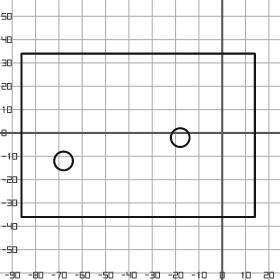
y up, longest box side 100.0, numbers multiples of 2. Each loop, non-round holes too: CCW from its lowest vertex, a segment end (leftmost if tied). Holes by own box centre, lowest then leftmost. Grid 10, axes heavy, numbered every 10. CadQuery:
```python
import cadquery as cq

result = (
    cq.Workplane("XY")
    .moveTo(-86.0, -36.0)
    .lineTo(14.0, -36.0)
    .lineTo(14.0, 34.0)
    .lineTo(-86.0, 34.0)
    .close()
    .moveTo(-68.0, -12.0)
    .circle(4.0)
    .moveTo(-18.0, -2.0)
    .circle(4.0)
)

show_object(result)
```